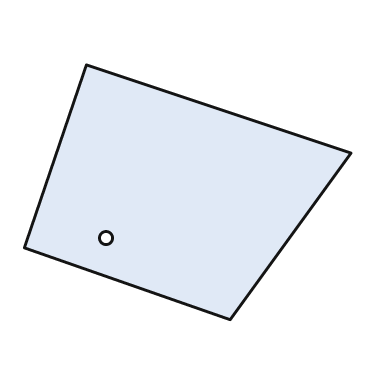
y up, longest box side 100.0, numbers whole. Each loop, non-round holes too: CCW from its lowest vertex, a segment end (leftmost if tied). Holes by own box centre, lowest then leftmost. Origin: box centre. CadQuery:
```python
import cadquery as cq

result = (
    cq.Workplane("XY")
    .moveTo(13.0, -39.0)
    .lineTo(50.0, 12.0)
    .lineTo(-31.0, 39.0)
    .lineTo(-50.0, -17.0)
    .close()
    .moveTo(-25.0, -14.0)
    .circle(2.0)
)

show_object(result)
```